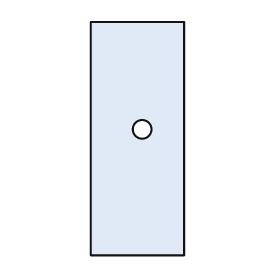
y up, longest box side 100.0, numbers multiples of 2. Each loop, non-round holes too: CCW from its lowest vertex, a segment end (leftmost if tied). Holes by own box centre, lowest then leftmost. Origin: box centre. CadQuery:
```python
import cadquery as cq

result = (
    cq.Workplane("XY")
    .moveTo(-20.0, -50.0)
    .lineTo(20.0, -50.0)
    .lineTo(20.0, 50.0)
    .lineTo(-20.0, 50.0)
    .close()
    .moveTo(2.0, 4.0)
    .circle(4.0)
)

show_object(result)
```